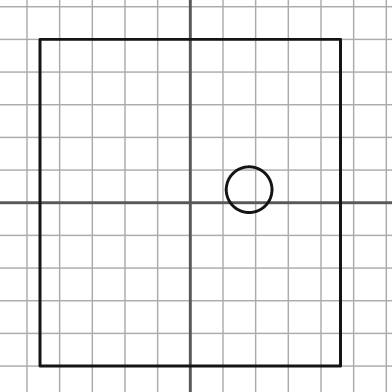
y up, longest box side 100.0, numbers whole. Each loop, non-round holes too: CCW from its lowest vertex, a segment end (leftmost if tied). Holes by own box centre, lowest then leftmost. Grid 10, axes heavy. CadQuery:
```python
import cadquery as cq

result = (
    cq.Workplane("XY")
    .moveTo(-46.0, -50.0)
    .lineTo(46.0, -50.0)
    .lineTo(46.0, 50.0)
    .lineTo(-46.0, 50.0)
    .close()
    .moveTo(18.0, 4.0)
    .circle(7.0)
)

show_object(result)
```